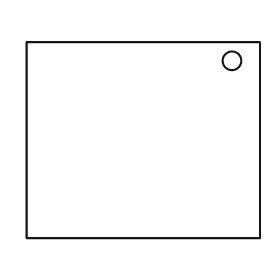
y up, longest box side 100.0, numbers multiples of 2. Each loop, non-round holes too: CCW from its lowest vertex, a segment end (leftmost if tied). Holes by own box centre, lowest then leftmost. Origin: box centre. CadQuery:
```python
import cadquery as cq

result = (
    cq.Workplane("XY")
    .moveTo(-50.0, -42.0)
    .lineTo(50.0, -42.0)
    .lineTo(50.0, 42.0)
    .lineTo(-50.0, 42.0)
    .close()
    .moveTo(38.0, 34.0)
    .circle(4.0)
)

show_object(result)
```